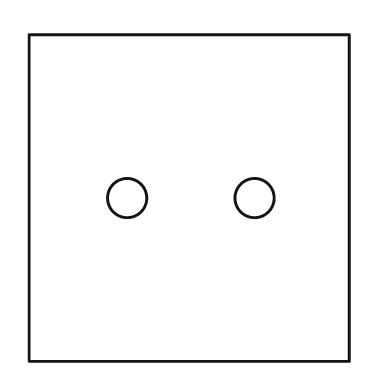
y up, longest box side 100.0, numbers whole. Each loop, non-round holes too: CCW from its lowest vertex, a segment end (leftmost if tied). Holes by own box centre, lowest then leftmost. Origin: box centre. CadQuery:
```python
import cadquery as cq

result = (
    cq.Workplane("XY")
    .moveTo(-49.0, -50.0)
    .lineTo(49.0, -50.0)
    .lineTo(49.0, 50.0)
    .lineTo(-49.0, 50.0)
    .close()
    .moveTo(-19.0, 0.0)
    .circle(6.0)
    .moveTo(20.0, 0.0)
    .circle(6.0)
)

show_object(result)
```